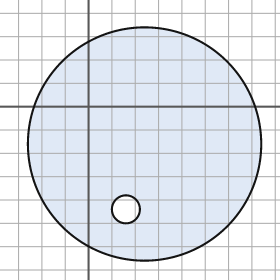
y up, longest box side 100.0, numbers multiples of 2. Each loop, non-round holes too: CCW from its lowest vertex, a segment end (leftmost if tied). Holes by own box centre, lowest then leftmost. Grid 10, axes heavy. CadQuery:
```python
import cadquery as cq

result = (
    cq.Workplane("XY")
    .moveTo(24.0, -16.0)
    .circle(50.0)
    .moveTo(16.0, -44.0)
    .circle(6.0)
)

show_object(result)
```